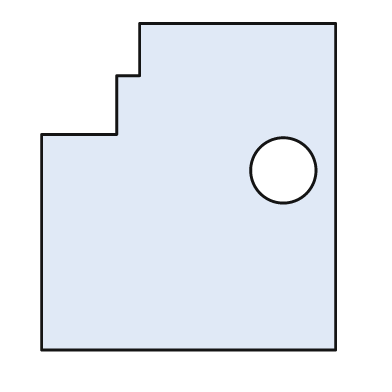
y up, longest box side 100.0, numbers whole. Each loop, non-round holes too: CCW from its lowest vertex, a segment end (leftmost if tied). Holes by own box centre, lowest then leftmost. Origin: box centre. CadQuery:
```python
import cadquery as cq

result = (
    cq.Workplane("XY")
    .moveTo(-45.0, -50.0)
    .lineTo(45.0, -50.0)
    .lineTo(45.0, 50.0)
    .lineTo(-15.0, 50.0)
    .lineTo(-15.0, 34.0)
    .lineTo(-22.0, 34.0)
    .lineTo(-22.0, 16.0)
    .lineTo(-45.0, 16.0)
    .close()
    .moveTo(29.0, 5.0)
    .circle(10.0)
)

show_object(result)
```